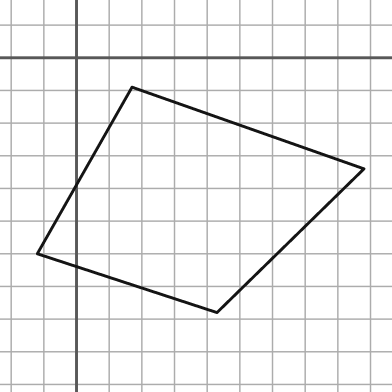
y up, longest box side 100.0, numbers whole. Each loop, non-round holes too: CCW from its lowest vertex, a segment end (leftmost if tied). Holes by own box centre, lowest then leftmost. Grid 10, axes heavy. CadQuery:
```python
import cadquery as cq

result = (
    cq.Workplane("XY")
    .moveTo(43.0, -78.0)
    .lineTo(88.0, -34.0)
    .lineTo(17.0, -9.0)
    .lineTo(-12.0, -60.0)
    .close()
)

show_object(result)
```